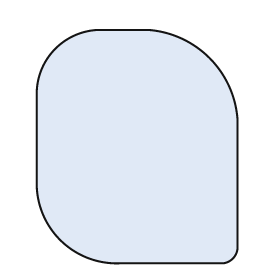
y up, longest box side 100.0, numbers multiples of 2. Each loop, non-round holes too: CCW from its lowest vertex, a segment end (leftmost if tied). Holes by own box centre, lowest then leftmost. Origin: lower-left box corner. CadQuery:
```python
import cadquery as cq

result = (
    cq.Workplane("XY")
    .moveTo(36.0, 0.0)
    .lineTo(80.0, 0.0)
    .threePointArc((84.0, 2.0), (86.0, 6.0))
    .lineTo(86.0, 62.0)
    .threePointArc((74.0, 88.0), (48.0, 100.0))
    .lineTo(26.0, 100.0)
    .threePointArc((8.0, 92.0), (0.0, 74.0))
    .lineTo(0.0, 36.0)
    .threePointArc((10.0, 10.0), (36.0, 0.0))
    .close()
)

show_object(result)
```